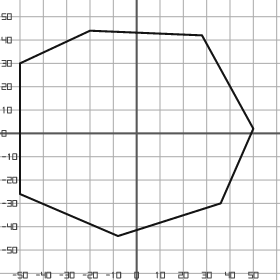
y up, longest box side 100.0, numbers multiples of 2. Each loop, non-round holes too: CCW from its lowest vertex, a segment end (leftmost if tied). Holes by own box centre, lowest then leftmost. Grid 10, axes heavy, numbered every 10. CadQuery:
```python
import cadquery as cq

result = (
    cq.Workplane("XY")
    .moveTo(-8.0, -44.0)
    .lineTo(36.0, -30.0)
    .lineTo(50.0, 2.0)
    .lineTo(28.0, 42.0)
    .lineTo(-20.0, 44.0)
    .lineTo(-50.0, 30.0)
    .lineTo(-50.0, -26.0)
    .close()
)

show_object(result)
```